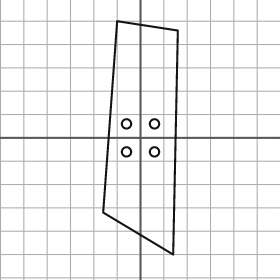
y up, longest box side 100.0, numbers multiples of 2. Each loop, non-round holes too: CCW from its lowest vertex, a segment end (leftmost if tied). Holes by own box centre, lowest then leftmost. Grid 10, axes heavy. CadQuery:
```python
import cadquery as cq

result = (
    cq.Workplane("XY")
    .moveTo(14.0, -50.0)
    .lineTo(16.0, 46.0)
    .lineTo(-10.0, 50.0)
    .lineTo(-16.0, -32.0)
    .close()
    .moveTo(-6.0, -6.0)
    .circle(2.0)
    .moveTo(6.0, -6.0)
    .circle(2.0)
    .moveTo(-6.0, 6.0)
    .circle(2.0)
    .moveTo(6.0, 6.0)
    .circle(2.0)
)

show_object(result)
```